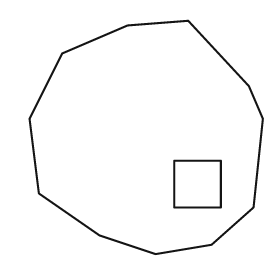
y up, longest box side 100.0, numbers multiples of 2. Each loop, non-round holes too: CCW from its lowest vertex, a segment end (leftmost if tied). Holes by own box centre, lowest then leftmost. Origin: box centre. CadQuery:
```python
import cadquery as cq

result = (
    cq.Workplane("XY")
    .moveTo(4.0, -50.0)
    .lineTo(28.0, -46.0)
    .lineTo(46.0, -30.0)
    .lineTo(50.0, 8.0)
    .lineTo(44.0, 22.0)
    .lineTo(18.0, 50.0)
    .lineTo(-8.0, 48.0)
    .lineTo(-36.0, 36.0)
    .lineTo(-50.0, 8.0)
    .lineTo(-46.0, -24.0)
    .lineTo(-20.0, -42.0)
    .close()
    .moveTo(12.0, -30.0)
    .lineTo(32.0, -30.0)
    .lineTo(32.0, -10.0)
    .lineTo(12.0, -10.0)
    .close()
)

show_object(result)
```